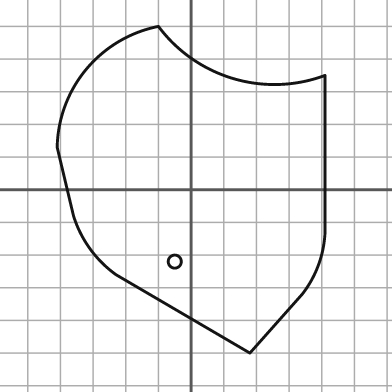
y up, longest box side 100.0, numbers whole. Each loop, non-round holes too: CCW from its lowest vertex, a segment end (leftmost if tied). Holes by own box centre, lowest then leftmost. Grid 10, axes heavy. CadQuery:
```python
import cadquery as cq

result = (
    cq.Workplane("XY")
    .moveTo(18.0, -50.0)
    .lineTo(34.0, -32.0)
    .threePointArc((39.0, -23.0), (41.0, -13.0))
    .lineTo(41.0, 35.0)
    .threePointArc((13.0, 34.0), (-10.0, 50.0))
    .threePointArc((-32.0, 37.0), (-41.0, 13.0))
    .lineTo(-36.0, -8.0)
    .threePointArc((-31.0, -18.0), (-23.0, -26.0))
    .close()
    .moveTo(-5.0, -22.0)
    .circle(2.0)
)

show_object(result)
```